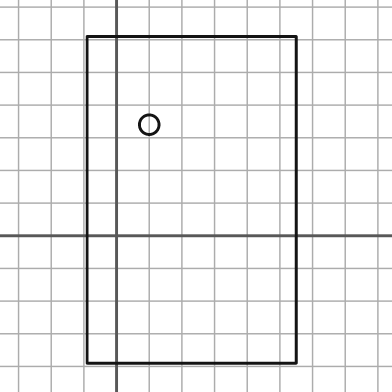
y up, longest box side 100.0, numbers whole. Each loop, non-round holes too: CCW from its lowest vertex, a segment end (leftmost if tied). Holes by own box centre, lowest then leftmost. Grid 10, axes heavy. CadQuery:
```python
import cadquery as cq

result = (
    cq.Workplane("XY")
    .moveTo(-9.0, -39.0)
    .lineTo(55.0, -39.0)
    .lineTo(55.0, 61.0)
    .lineTo(-9.0, 61.0)
    .close()
    .moveTo(10.0, 34.0)
    .circle(3.0)
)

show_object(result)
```